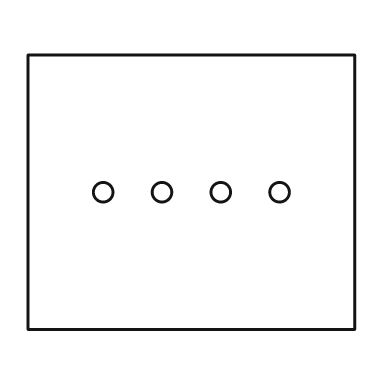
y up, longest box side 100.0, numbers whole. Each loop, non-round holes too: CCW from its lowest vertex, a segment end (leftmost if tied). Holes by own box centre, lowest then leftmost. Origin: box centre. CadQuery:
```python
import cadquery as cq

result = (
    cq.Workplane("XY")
    .moveTo(-50.0, -42.0)
    .lineTo(50.0, -42.0)
    .lineTo(50.0, 42.0)
    .lineTo(-50.0, 42.0)
    .close()
    .moveTo(-27.0, 0.0)
    .circle(3.0)
    .moveTo(-9.0, 0.0)
    .circle(3.0)
    .moveTo(9.0, 0.0)
    .circle(3.0)
    .moveTo(27.0, 0.0)
    .circle(3.0)
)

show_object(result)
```